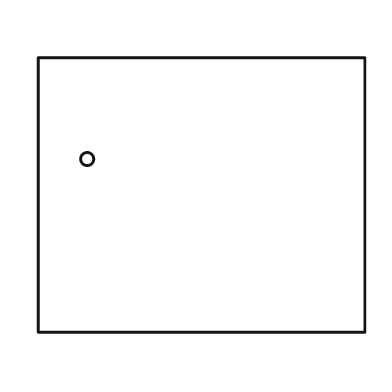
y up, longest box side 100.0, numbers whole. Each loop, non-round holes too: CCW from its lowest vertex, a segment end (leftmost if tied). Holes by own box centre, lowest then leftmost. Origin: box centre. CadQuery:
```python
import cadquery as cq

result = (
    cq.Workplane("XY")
    .moveTo(-50.0, -42.0)
    .lineTo(50.0, -42.0)
    .lineTo(50.0, 42.0)
    .lineTo(-50.0, 42.0)
    .close()
    .moveTo(-35.0, 11.0)
    .circle(2.0)
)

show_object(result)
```